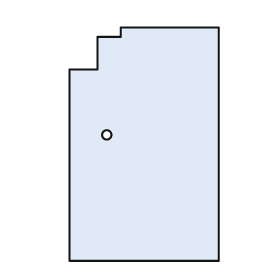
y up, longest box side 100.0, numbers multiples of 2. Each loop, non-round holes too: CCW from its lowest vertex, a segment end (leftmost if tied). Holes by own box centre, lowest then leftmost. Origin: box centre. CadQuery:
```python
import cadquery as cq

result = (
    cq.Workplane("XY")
    .moveTo(-32.0, -50.0)
    .lineTo(32.0, -50.0)
    .lineTo(32.0, 50.0)
    .lineTo(-10.0, 50.0)
    .lineTo(-10.0, 46.0)
    .lineTo(-20.0, 46.0)
    .lineTo(-20.0, 32.0)
    .lineTo(-32.0, 32.0)
    .close()
    .moveTo(-16.0, 4.0)
    .circle(2.0)
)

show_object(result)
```